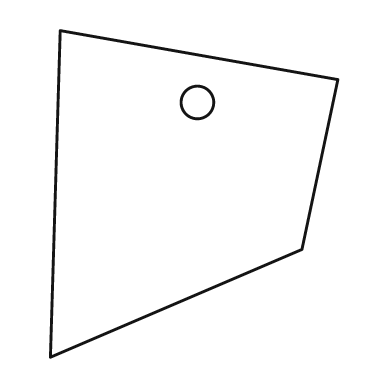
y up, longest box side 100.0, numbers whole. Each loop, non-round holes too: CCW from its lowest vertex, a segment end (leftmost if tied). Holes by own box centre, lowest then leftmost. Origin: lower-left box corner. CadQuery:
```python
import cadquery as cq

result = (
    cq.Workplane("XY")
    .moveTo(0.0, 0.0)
    .lineTo(77.0, 33.0)
    .lineTo(88.0, 85.0)
    .lineTo(3.0, 100.0)
    .close()
    .moveTo(45.0, 78.0)
    .circle(5.0)
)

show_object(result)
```